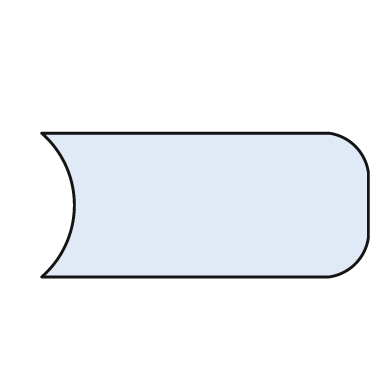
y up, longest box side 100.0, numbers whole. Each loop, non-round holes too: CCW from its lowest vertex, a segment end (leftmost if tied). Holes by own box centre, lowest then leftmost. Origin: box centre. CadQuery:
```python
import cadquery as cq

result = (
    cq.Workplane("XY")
    .moveTo(-50.0, -22.0)
    .lineTo(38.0, -22.0)
    .threePointArc((46.0, -18.0), (50.0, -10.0))
    .lineTo(50.0, 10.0)
    .threePointArc((46.0, 18.0), (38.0, 22.0))
    .lineTo(-50.0, 22.0)
    .threePointArc((-40.0, 0.0), (-50.0, -22.0))
    .close()
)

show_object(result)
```